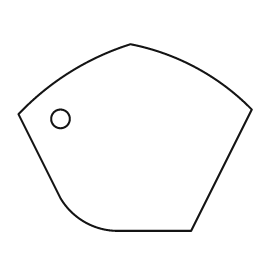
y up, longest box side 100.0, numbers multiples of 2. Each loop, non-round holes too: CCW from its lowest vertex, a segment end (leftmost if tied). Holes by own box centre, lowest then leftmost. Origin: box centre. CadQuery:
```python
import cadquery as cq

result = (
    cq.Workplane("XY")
    .moveTo(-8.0, -40.0)
    .lineTo(24.0, -40.0)
    .lineTo(50.0, 12.0)
    .threePointArc((26.0, 30.0), (-2.0, 40.0))
    .threePointArc((-28.0, 28.0), (-50.0, 10.0))
    .lineTo(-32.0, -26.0)
    .threePointArc((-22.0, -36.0), (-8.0, -40.0))
    .close()
    .moveTo(-32.0, 8.0)
    .circle(4.0)
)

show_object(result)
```